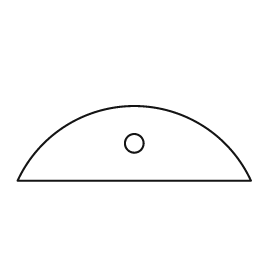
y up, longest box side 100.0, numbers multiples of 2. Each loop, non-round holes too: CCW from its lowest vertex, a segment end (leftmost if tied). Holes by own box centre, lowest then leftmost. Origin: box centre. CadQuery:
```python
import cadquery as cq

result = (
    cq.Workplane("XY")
    .moveTo(-50.0, -16.0)
    .lineTo(50.0, -16.0)
    .threePointArc((0.0, 16.0), (-50.0, -16.0))
    .close()
    .moveTo(0.0, 0.0)
    .circle(4.0)
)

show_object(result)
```